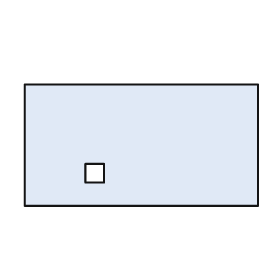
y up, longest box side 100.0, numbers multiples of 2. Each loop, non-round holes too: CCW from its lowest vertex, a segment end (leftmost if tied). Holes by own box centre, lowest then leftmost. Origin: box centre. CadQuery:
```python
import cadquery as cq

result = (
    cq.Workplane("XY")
    .moveTo(-50.0, -26.0)
    .lineTo(50.0, -26.0)
    .lineTo(50.0, 26.0)
    .lineTo(-50.0, 26.0)
    .close()
    .moveTo(-24.0, -16.0)
    .lineTo(-16.0, -16.0)
    .lineTo(-16.0, -8.0)
    .lineTo(-24.0, -8.0)
    .close()
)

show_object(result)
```